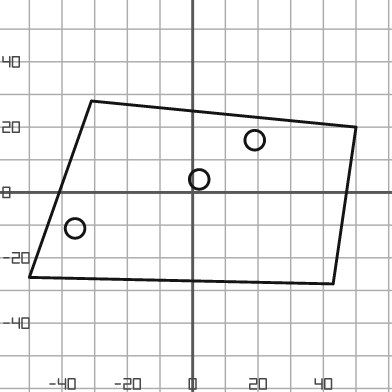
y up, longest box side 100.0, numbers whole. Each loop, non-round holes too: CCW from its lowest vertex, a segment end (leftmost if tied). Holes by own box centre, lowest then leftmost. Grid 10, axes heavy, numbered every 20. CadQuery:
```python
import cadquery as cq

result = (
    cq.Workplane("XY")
    .moveTo(43.0, -28.0)
    .lineTo(50.0, 20.0)
    .lineTo(-31.0, 28.0)
    .lineTo(-50.0, -26.0)
    .close()
    .moveTo(-36.0, -11.0)
    .circle(3.0)
    .moveTo(2.0, 4.0)
    .circle(3.0)
    .moveTo(19.0, 16.0)
    .circle(3.0)
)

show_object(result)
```